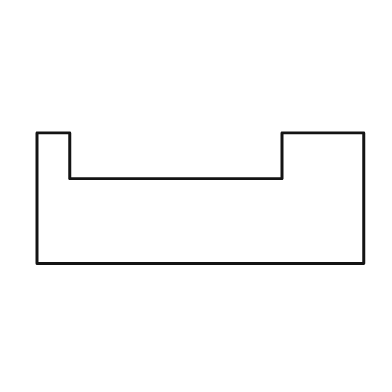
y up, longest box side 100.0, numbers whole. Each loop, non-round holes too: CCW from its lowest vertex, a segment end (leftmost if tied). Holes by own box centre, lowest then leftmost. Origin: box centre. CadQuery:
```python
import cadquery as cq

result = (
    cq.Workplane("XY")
    .moveTo(-50.0, -20.0)
    .lineTo(50.0, -20.0)
    .lineTo(50.0, 20.0)
    .lineTo(25.0, 20.0)
    .lineTo(25.0, 6.0)
    .lineTo(-40.0, 6.0)
    .lineTo(-40.0, 20.0)
    .lineTo(-50.0, 20.0)
    .close()
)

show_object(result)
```